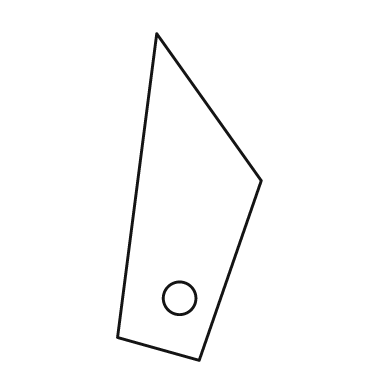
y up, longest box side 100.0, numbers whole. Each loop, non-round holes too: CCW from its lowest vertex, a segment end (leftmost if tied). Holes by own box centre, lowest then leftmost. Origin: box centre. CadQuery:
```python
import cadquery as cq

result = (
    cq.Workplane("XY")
    .moveTo(3.0, -50.0)
    .lineTo(22.0, 5.0)
    .lineTo(-10.0, 50.0)
    .lineTo(-22.0, -43.0)
    .close()
    .moveTo(-3.0, -31.0)
    .circle(5.0)
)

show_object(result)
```